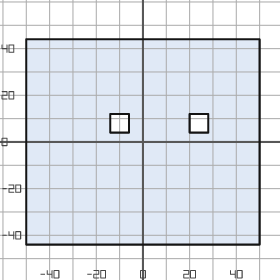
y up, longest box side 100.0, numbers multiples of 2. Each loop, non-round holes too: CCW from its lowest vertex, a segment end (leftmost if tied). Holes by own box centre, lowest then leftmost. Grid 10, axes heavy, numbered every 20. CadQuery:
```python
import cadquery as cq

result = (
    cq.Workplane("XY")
    .moveTo(-50.0, -44.0)
    .lineTo(50.0, -44.0)
    .lineTo(50.0, 44.0)
    .lineTo(-50.0, 44.0)
    .close()
    .moveTo(-14.0, 4.0)
    .lineTo(-6.0, 4.0)
    .lineTo(-6.0, 12.0)
    .lineTo(-14.0, 12.0)
    .close()
    .moveTo(20.0, 4.0)
    .lineTo(28.0, 4.0)
    .lineTo(28.0, 12.0)
    .lineTo(20.0, 12.0)
    .close()
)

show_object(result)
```